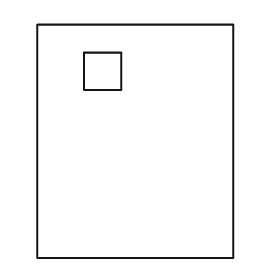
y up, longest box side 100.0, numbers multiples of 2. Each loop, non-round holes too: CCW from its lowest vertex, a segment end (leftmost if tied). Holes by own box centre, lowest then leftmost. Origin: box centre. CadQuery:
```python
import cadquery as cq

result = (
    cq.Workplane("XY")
    .moveTo(-42.0, -50.0)
    .lineTo(42.0, -50.0)
    .lineTo(42.0, 50.0)
    .lineTo(-42.0, 50.0)
    .close()
    .moveTo(-22.0, 22.0)
    .lineTo(-6.0, 22.0)
    .lineTo(-6.0, 38.0)
    .lineTo(-22.0, 38.0)
    .close()
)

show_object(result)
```